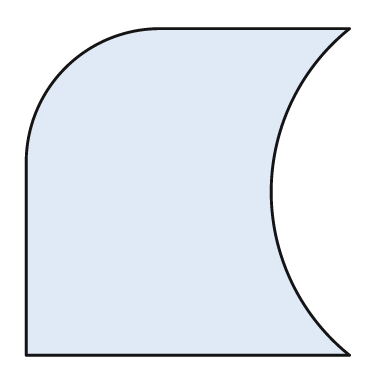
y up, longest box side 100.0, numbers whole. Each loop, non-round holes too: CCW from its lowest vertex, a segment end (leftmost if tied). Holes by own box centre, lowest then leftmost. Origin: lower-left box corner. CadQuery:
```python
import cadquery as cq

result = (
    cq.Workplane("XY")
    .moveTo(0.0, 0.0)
    .lineTo(99.0, 0.0)
    .threePointArc((75.0, 50.0), (99.0, 100.0))
    .lineTo(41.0, 100.0)
    .threePointArc((12.0, 88.0), (0.0, 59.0))
    .close()
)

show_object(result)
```